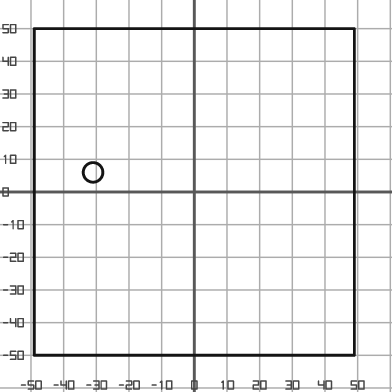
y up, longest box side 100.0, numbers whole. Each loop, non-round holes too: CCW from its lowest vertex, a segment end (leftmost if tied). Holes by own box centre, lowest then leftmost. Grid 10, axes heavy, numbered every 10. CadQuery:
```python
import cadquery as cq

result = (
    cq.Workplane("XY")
    .moveTo(-49.0, -50.0)
    .lineTo(49.0, -50.0)
    .lineTo(49.0, 50.0)
    .lineTo(-49.0, 50.0)
    .close()
    .moveTo(-31.0, 6.0)
    .circle(3.0)
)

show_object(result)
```